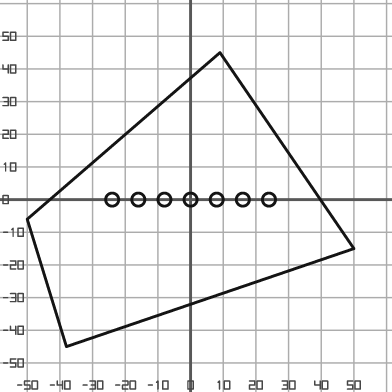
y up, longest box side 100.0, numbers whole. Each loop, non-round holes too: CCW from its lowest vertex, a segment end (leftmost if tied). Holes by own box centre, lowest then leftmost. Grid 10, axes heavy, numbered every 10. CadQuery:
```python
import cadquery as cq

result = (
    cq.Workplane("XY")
    .moveTo(-38.0, -45.0)
    .lineTo(50.0, -15.0)
    .lineTo(9.0, 45.0)
    .lineTo(-50.0, -6.0)
    .close()
    .moveTo(-24.0, 0.0)
    .circle(2.0)
    .moveTo(-16.0, 0.0)
    .circle(2.0)
    .moveTo(-8.0, 0.0)
    .circle(2.0)
    .moveTo(0.0, 0.0)
    .circle(2.0)
    .moveTo(8.0, 0.0)
    .circle(2.0)
    .moveTo(16.0, 0.0)
    .circle(2.0)
    .moveTo(24.0, 0.0)
    .circle(2.0)
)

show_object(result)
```